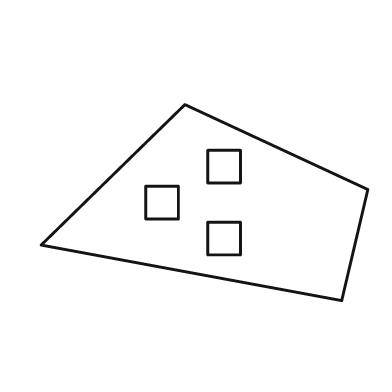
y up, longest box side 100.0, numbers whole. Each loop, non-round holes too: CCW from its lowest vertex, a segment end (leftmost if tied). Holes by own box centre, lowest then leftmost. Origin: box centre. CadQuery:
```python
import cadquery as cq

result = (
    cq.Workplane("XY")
    .moveTo(42.0, -30.0)
    .lineTo(50.0, 4.0)
    .lineTo(-6.0, 30.0)
    .lineTo(-50.0, -13.0)
    .close()
    .moveTo(1.0, -16.0)
    .lineTo(11.0, -16.0)
    .lineTo(11.0, -6.0)
    .lineTo(1.0, -6.0)
    .close()
    .moveTo(-18.0, -5.0)
    .lineTo(-8.0, -5.0)
    .lineTo(-8.0, 5.0)
    .lineTo(-18.0, 5.0)
    .close()
    .moveTo(1.0, 6.0)
    .lineTo(11.0, 6.0)
    .lineTo(11.0, 16.0)
    .lineTo(1.0, 16.0)
    .close()
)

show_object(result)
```